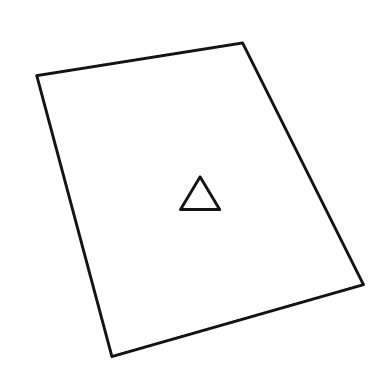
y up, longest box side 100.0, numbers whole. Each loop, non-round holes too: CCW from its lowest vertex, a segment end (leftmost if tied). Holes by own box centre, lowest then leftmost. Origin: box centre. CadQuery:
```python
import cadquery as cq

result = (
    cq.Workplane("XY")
    .moveTo(-27.0, -48.0)
    .lineTo(50.0, -26.0)
    .lineTo(13.0, 48.0)
    .lineTo(-50.0, 38.0)
    .close()
    .moveTo(-6.0, -3.0)
    .lineTo(6.0, -3.0)
    .lineTo(0.0, 7.0)
    .close()
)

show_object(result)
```